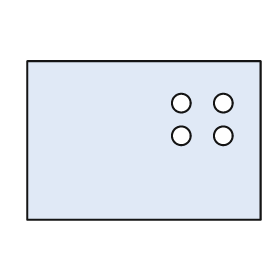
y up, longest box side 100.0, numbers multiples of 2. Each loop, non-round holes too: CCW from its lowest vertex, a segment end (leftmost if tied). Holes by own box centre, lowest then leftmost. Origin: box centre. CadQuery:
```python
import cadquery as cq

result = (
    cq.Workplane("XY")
    .moveTo(-50.0, -34.0)
    .lineTo(50.0, -34.0)
    .lineTo(50.0, 34.0)
    .lineTo(-50.0, 34.0)
    .close()
    .moveTo(16.0, 2.0)
    .circle(4.0)
    .moveTo(34.0, 2.0)
    .circle(4.0)
    .moveTo(16.0, 16.0)
    .circle(4.0)
    .moveTo(34.0, 16.0)
    .circle(4.0)
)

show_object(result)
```